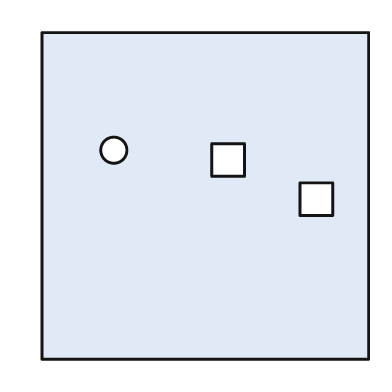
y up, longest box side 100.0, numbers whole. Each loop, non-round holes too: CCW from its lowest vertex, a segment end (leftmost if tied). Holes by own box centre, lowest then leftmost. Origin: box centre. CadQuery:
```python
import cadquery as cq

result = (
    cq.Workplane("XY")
    .moveTo(-50.0, -50.0)
    .lineTo(50.0, -50.0)
    .lineTo(50.0, 50.0)
    .lineTo(-50.0, 50.0)
    .close()
    .moveTo(29.0, -6.0)
    .lineTo(39.0, -6.0)
    .lineTo(39.0, 4.0)
    .lineTo(29.0, 4.0)
    .close()
    .moveTo(2.0, 6.0)
    .lineTo(12.0, 6.0)
    .lineTo(12.0, 16.0)
    .lineTo(2.0, 16.0)
    .close()
    .moveTo(-28.0, 14.0)
    .circle(4.0)
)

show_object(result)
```